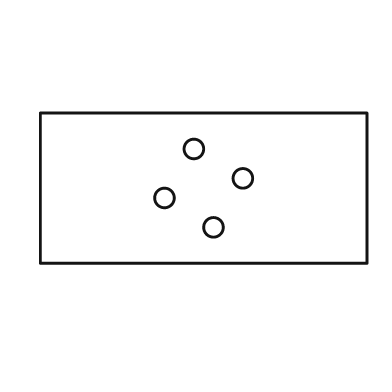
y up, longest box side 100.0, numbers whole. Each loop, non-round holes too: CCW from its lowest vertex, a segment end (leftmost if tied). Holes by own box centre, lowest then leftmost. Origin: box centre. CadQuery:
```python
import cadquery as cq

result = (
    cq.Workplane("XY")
    .moveTo(-50.0, -23.0)
    .lineTo(50.0, -23.0)
    .lineTo(50.0, 23.0)
    .lineTo(-50.0, 23.0)
    .close()
    .moveTo(3.0, -12.0)
    .circle(3.0)
    .moveTo(-12.0, -3.0)
    .circle(3.0)
    .moveTo(12.0, 3.0)
    .circle(3.0)
    .moveTo(-3.0, 12.0)
    .circle(3.0)
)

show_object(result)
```